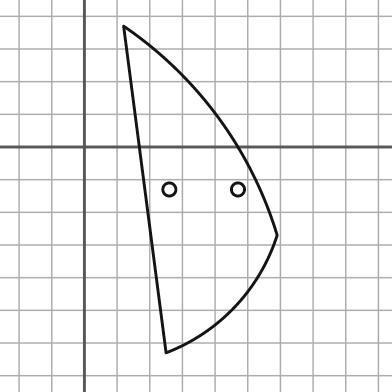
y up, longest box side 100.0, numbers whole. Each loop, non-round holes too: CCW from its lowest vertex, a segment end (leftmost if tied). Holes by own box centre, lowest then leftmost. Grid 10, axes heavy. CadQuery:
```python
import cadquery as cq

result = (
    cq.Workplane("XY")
    .moveTo(25.0, -63.0)
    .threePointArc((46.0, -49.0), (59.0, -27.0))
    .threePointArc((41.0, 9.0), (12.0, 37.0))
    .close()
    .moveTo(26.0, -13.0)
    .circle(2.0)
    .moveTo(47.0, -13.0)
    .circle(2.0)
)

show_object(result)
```